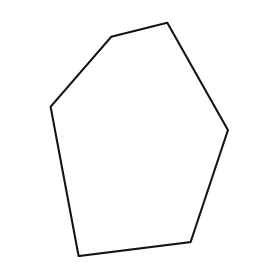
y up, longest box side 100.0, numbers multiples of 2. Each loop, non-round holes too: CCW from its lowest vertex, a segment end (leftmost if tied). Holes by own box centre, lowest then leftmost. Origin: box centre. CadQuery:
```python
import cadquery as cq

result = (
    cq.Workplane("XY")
    .moveTo(-26.0, -50.0)
    .lineTo(22.0, -44.0)
    .lineTo(38.0, 4.0)
    .lineTo(12.0, 50.0)
    .lineTo(-12.0, 44.0)
    .lineTo(-38.0, 14.0)
    .close()
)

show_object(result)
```